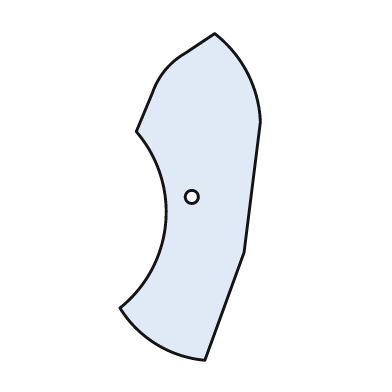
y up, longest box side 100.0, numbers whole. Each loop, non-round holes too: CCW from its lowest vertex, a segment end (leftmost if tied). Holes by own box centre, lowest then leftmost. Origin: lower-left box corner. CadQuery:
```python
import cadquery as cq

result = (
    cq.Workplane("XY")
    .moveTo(26.0, 0.0)
    .lineTo(38.0, 33.0)
    .lineTo(43.0, 73.0)
    .threePointArc((39.0, 88.0), (29.0, 100.0))
    .lineTo(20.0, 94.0)
    .threePointArc((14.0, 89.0), (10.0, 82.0))
    .lineTo(5.0, 70.0)
    .threePointArc((14.0, 42.0), (0.0, 16.0))
    .threePointArc((11.0, 5.0), (26.0, 0.0))
    .close()
    .moveTo(22.0, 50.0)
    .circle(2.0)
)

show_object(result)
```